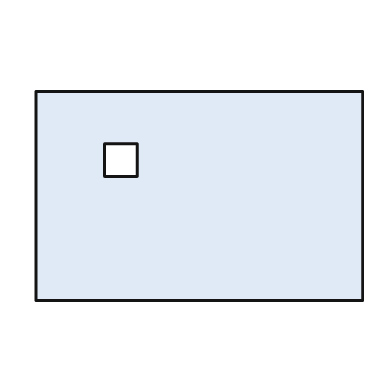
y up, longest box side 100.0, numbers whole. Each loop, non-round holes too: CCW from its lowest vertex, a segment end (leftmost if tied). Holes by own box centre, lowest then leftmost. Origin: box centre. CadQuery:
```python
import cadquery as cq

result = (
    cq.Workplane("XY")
    .moveTo(-50.0, -32.0)
    .lineTo(50.0, -32.0)
    .lineTo(50.0, 32.0)
    .lineTo(-50.0, 32.0)
    .close()
    .moveTo(-29.0, 6.0)
    .lineTo(-19.0, 6.0)
    .lineTo(-19.0, 16.0)
    .lineTo(-29.0, 16.0)
    .close()
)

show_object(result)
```